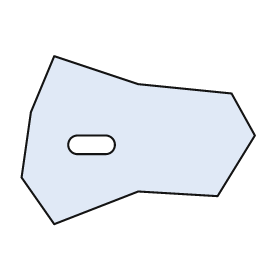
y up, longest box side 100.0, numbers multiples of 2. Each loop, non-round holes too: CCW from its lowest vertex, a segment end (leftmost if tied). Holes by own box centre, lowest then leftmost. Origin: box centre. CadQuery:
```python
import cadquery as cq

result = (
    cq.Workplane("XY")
    .moveTo(-36.0, -36.0)
    .lineTo(0.0, -22.0)
    .lineTo(34.0, -24.0)
    .lineTo(50.0, 2.0)
    .lineTo(40.0, 20.0)
    .lineTo(0.0, 24.0)
    .lineTo(-36.0, 36.0)
    .lineTo(-46.0, 12.0)
    .lineTo(-50.0, -16.0)
    .close()
    .moveTo(-26.0, -6.0)
    .lineTo(-14.0, -6.0)
    .threePointArc((-10.0, -2.0), (-14.0, 2.0))
    .lineTo(-26.0, 2.0)
    .threePointArc((-30.0, -2.0), (-26.0, -6.0))
    .close()
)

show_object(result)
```